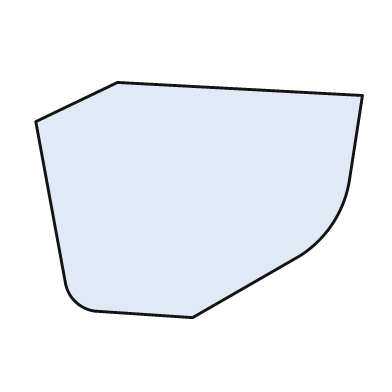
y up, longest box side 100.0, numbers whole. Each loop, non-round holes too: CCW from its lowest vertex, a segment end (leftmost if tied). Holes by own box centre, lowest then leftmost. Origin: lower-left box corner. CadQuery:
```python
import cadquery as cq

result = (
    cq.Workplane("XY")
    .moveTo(48.0, 0.0)
    .lineTo(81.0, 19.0)
    .threePointArc((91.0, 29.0), (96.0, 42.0))
    .lineTo(100.0, 68.0)
    .lineTo(25.0, 72.0)
    .lineTo(0.0, 60.0)
    .lineTo(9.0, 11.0)
    .threePointArc((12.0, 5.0), (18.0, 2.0))
    .close()
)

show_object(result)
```